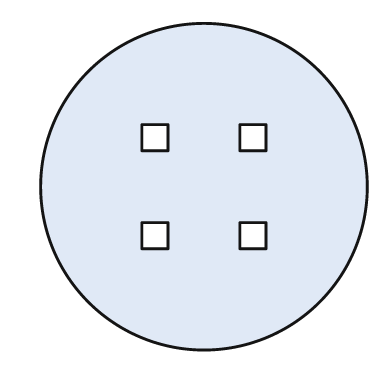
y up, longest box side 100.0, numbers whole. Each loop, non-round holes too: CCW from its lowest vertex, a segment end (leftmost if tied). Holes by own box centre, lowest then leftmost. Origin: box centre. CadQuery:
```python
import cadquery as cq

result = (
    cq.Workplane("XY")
    .moveTo(0.0, 0.0)
    .circle(50.0)
    .moveTo(-19.0, -19.0)
    .lineTo(-11.0, -19.0)
    .lineTo(-11.0, -11.0)
    .lineTo(-19.0, -11.0)
    .close()
    .moveTo(11.0, -19.0)
    .lineTo(19.0, -19.0)
    .lineTo(19.0, -11.0)
    .lineTo(11.0, -11.0)
    .close()
    .moveTo(-19.0, 11.0)
    .lineTo(-11.0, 11.0)
    .lineTo(-11.0, 19.0)
    .lineTo(-19.0, 19.0)
    .close()
    .moveTo(11.0, 11.0)
    .lineTo(19.0, 11.0)
    .lineTo(19.0, 19.0)
    .lineTo(11.0, 19.0)
    .close()
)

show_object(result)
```